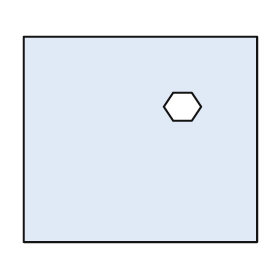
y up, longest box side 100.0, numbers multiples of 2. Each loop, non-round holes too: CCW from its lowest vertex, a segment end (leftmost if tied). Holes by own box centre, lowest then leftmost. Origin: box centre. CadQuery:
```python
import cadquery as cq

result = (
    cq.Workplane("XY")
    .moveTo(-50.0, -44.0)
    .lineTo(50.0, -44.0)
    .lineTo(50.0, 44.0)
    .lineTo(-50.0, 44.0)
    .close()
    .moveTo(14.0, 8.0)
    .lineTo(22.0, 8.0)
    .lineTo(26.0, 14.0)
    .lineTo(22.0, 20.0)
    .lineTo(14.0, 20.0)
    .lineTo(10.0, 14.0)
    .close()
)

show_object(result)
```